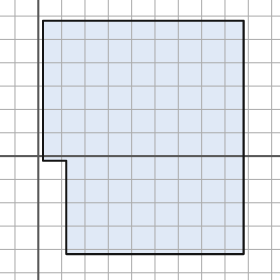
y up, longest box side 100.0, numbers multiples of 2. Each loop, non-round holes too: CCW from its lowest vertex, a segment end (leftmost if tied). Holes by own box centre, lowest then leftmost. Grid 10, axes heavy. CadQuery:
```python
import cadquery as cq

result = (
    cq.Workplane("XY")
    .moveTo(12.0, -42.0)
    .lineTo(88.0, -42.0)
    .lineTo(88.0, 58.0)
    .lineTo(2.0, 58.0)
    .lineTo(2.0, -2.0)
    .lineTo(12.0, -2.0)
    .close()
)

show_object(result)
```